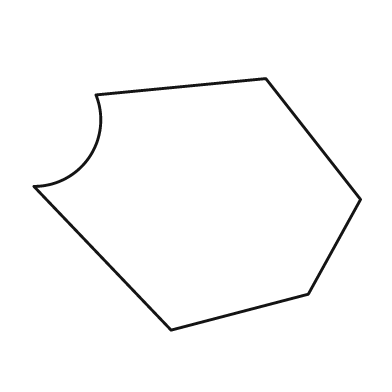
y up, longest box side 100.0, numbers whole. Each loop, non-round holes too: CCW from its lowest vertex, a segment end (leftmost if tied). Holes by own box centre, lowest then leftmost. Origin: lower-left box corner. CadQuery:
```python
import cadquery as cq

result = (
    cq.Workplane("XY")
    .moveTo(42.0, 0.0)
    .lineTo(84.0, 11.0)
    .lineTo(100.0, 40.0)
    .lineTo(71.0, 77.0)
    .lineTo(19.0, 72.0)
    .threePointArc((17.0, 53.0), (0.0, 44.0))
    .close()
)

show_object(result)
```